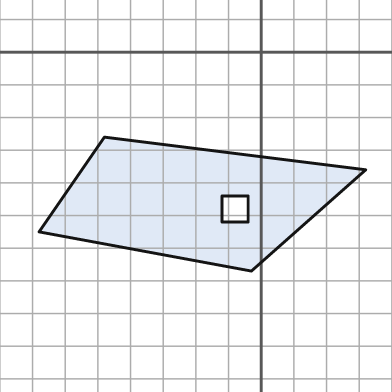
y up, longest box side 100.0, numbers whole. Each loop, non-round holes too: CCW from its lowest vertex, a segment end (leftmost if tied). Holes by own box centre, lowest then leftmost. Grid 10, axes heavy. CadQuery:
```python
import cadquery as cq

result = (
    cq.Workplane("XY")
    .moveTo(-3.0, -67.0)
    .lineTo(32.0, -36.0)
    .lineTo(-48.0, -26.0)
    .lineTo(-68.0, -55.0)
    .close()
    .moveTo(-12.0, -52.0)
    .lineTo(-4.0, -52.0)
    .lineTo(-4.0, -44.0)
    .lineTo(-12.0, -44.0)
    .close()
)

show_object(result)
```